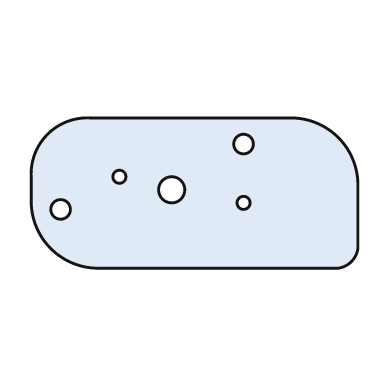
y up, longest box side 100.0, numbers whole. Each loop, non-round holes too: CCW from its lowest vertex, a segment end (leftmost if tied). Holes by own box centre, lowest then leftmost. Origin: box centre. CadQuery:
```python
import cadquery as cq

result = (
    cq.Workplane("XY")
    .moveTo(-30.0, -23.0)
    .lineTo(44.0, -23.0)
    .threePointArc((48.0, -21.0), (50.0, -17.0))
    .lineTo(50.0, 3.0)
    .threePointArc((44.0, 17.0), (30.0, 23.0))
    .lineTo(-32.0, 23.0)
    .threePointArc((-45.0, 18.0), (-50.0, 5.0))
    .lineTo(-50.0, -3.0)
    .threePointArc((-44.0, -17.0), (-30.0, -23.0))
    .close()
    .moveTo(-41.0, -5.0)
    .circle(3.0)
    .moveTo(15.0, -3.0)
    .circle(2.0)
    .moveTo(-7.0, 1.0)
    .circle(4.0)
    .moveTo(-23.0, 5.0)
    .circle(2.0)
    .moveTo(15.0, 15.0)
    .circle(3.0)
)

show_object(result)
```